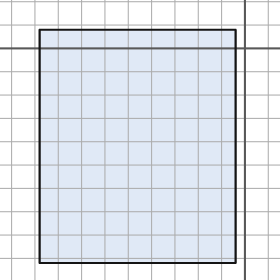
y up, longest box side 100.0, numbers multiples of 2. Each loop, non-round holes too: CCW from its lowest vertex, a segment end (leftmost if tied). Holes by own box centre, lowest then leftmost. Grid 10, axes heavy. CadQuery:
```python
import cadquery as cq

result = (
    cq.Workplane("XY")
    .moveTo(-88.0, -92.0)
    .lineTo(-4.0, -92.0)
    .lineTo(-4.0, 8.0)
    .lineTo(-88.0, 8.0)
    .close()
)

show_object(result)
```